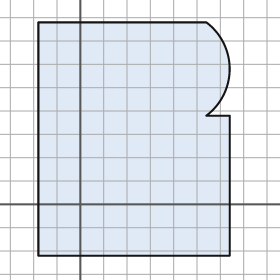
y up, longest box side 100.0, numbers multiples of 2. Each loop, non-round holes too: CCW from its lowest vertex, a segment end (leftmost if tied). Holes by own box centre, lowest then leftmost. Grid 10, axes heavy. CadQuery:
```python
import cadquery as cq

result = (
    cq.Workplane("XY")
    .moveTo(-18.0, -22.0)
    .lineTo(64.0, -22.0)
    .lineTo(64.0, 38.0)
    .lineTo(54.0, 38.0)
    .threePointArc((64.0, 58.0), (54.0, 78.0))
    .lineTo(-18.0, 78.0)
    .close()
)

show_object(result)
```